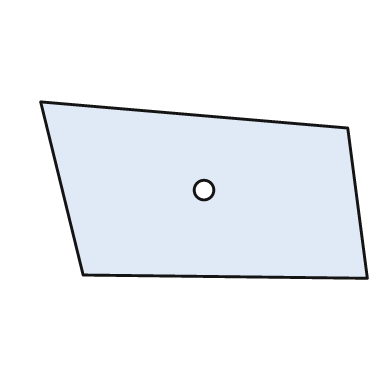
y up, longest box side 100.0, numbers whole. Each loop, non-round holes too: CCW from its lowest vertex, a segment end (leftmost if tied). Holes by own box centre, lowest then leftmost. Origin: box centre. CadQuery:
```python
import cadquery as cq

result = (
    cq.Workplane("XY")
    .moveTo(50.0, -27.0)
    .lineTo(44.0, 19.0)
    .lineTo(-50.0, 27.0)
    .lineTo(-37.0, -26.0)
    .close()
    .moveTo(0.0, 0.0)
    .circle(3.0)
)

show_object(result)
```